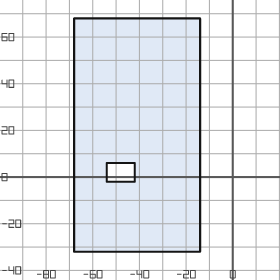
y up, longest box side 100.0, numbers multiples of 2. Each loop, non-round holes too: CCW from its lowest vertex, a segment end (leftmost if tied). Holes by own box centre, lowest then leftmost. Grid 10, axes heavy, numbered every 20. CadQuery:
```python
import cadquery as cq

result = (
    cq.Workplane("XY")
    .moveTo(-68.0, -32.0)
    .lineTo(-14.0, -32.0)
    .lineTo(-14.0, 68.0)
    .lineTo(-68.0, 68.0)
    .close()
    .moveTo(-54.0, -2.0)
    .lineTo(-42.0, -2.0)
    .lineTo(-42.0, 6.0)
    .lineTo(-54.0, 6.0)
    .close()
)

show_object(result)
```